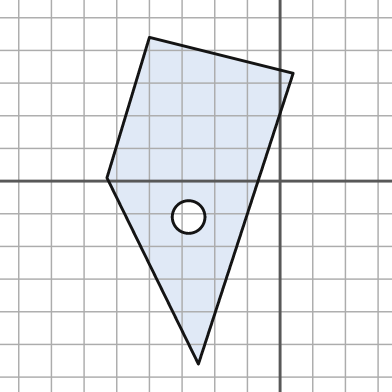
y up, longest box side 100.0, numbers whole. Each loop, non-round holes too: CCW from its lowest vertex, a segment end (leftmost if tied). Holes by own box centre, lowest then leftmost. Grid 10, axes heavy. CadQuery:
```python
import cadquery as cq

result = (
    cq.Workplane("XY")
    .moveTo(-25.0, -56.0)
    .lineTo(4.0, 33.0)
    .lineTo(-40.0, 44.0)
    .lineTo(-53.0, 1.0)
    .close()
    .moveTo(-28.0, -11.0)
    .circle(5.0)
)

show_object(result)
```